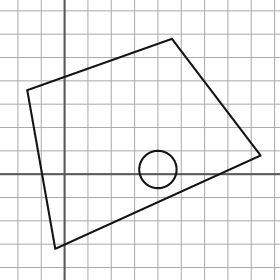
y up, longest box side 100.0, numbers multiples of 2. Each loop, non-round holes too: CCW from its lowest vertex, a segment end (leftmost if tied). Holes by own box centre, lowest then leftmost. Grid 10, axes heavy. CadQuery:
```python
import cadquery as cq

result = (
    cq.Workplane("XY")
    .moveTo(-4.0, -32.0)
    .lineTo(84.0, 8.0)
    .lineTo(46.0, 58.0)
    .lineTo(-16.0, 36.0)
    .close()
    .moveTo(40.0, 2.0)
    .circle(8.0)
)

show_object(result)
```